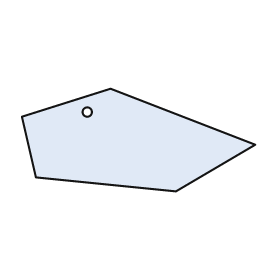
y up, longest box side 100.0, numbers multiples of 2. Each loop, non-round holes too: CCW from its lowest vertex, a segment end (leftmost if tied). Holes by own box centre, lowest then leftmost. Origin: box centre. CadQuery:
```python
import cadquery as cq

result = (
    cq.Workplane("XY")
    .moveTo(16.0, -22.0)
    .lineTo(50.0, -2.0)
    .lineTo(-12.0, 22.0)
    .lineTo(-50.0, 10.0)
    .lineTo(-44.0, -16.0)
    .close()
    .moveTo(-22.0, 12.0)
    .circle(2.0)
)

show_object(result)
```